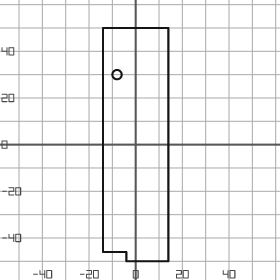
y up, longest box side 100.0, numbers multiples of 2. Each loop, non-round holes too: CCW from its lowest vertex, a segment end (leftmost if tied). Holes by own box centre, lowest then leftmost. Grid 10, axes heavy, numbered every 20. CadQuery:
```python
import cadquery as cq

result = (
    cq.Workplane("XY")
    .moveTo(-4.0, -50.0)
    .lineTo(14.0, -50.0)
    .lineTo(14.0, 50.0)
    .lineTo(-14.0, 50.0)
    .lineTo(-14.0, -46.0)
    .lineTo(-4.0, -46.0)
    .close()
    .moveTo(-8.0, 30.0)
    .circle(2.0)
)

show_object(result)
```